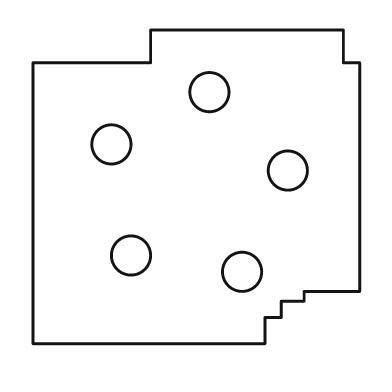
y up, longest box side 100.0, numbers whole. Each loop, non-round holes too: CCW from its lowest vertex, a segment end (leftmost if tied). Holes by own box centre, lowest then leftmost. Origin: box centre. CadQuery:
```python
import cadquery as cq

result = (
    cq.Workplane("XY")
    .moveTo(-50.0, -48.0)
    .lineTo(21.0, -48.0)
    .lineTo(21.0, -40.0)
    .lineTo(26.0, -40.0)
    .lineTo(26.0, -35.0)
    .lineTo(33.0, -35.0)
    .lineTo(33.0, -32.0)
    .lineTo(50.0, -32.0)
    .lineTo(50.0, 38.0)
    .lineTo(45.0, 38.0)
    .lineTo(45.0, 48.0)
    .lineTo(-14.0, 48.0)
    .lineTo(-14.0, 38.0)
    .lineTo(-50.0, 38.0)
    .close()
    .moveTo(14.0, -26.0)
    .circle(6.0)
    .moveTo(-20.0, -21.0)
    .circle(6.0)
    .moveTo(28.0, 5.0)
    .circle(6.0)
    .moveTo(-26.0, 13.0)
    .circle(6.0)
    .moveTo(4.0, 29.0)
    .circle(6.0)
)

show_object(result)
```